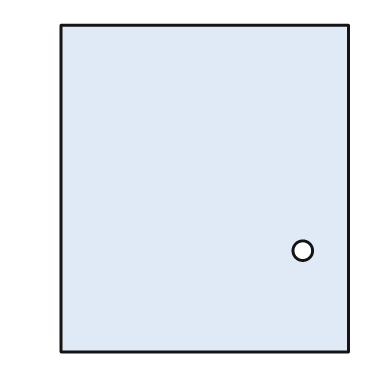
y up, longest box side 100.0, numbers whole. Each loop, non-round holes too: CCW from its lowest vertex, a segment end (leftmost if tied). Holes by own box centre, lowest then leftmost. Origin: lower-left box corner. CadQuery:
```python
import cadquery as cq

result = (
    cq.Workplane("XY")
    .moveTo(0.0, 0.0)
    .lineTo(88.0, 0.0)
    .lineTo(88.0, 100.0)
    .lineTo(0.0, 100.0)
    .close()
    .moveTo(74.0, 31.0)
    .circle(3.0)
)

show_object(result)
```